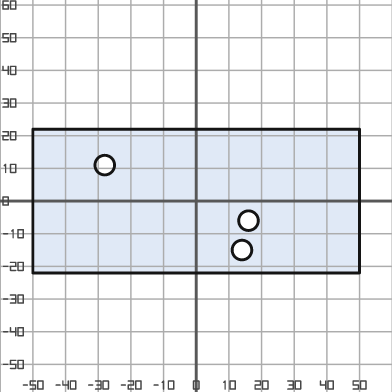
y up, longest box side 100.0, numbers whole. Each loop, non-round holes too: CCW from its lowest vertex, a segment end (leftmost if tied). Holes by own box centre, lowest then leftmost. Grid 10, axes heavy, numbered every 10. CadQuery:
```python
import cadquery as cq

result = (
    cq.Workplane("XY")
    .moveTo(-50.0, -22.0)
    .lineTo(50.0, -22.0)
    .lineTo(50.0, 22.0)
    .lineTo(-50.0, 22.0)
    .close()
    .moveTo(14.0, -15.0)
    .circle(3.0)
    .moveTo(16.0, -6.0)
    .circle(3.0)
    .moveTo(-28.0, 11.0)
    .circle(3.0)
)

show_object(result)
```